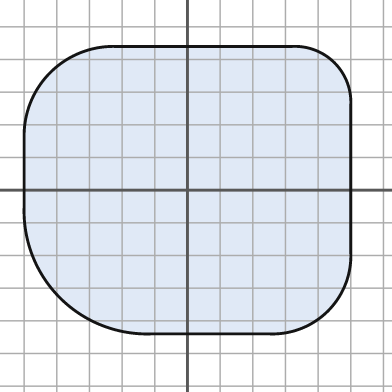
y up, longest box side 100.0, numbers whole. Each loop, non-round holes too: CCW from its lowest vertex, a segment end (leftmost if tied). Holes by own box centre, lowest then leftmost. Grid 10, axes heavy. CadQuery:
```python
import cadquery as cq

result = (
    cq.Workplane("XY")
    .moveTo(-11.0, -44.0)
    .lineTo(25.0, -44.0)
    .threePointArc((43.0, -37.0), (50.0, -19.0))
    .lineTo(50.0, 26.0)
    .threePointArc((45.0, 39.0), (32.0, 44.0))
    .lineTo(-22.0, 44.0)
    .threePointArc((-42.0, 36.0), (-50.0, 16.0))
    .lineTo(-50.0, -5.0)
    .threePointArc((-39.0, -33.0), (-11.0, -44.0))
    .close()
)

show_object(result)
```